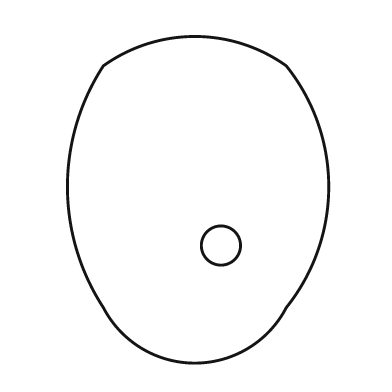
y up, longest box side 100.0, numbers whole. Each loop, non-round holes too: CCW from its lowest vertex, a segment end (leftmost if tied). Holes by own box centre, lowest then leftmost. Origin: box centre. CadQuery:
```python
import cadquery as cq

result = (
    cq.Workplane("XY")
    .moveTo(-29.0, -33.0)
    .threePointArc((-1.0, -50.0), (27.0, -33.0))
    .threePointArc((40.0, 4.0), (27.0, 41.0))
    .threePointArc((-1.0, 50.0), (-29.0, 41.0))
    .threePointArc((-40.0, 4.0), (-29.0, -33.0))
    .close()
    .moveTo(7.0, -14.0)
    .circle(6.0)
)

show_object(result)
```